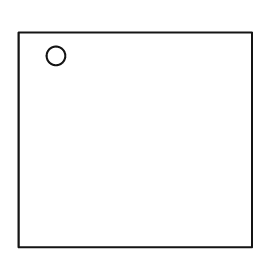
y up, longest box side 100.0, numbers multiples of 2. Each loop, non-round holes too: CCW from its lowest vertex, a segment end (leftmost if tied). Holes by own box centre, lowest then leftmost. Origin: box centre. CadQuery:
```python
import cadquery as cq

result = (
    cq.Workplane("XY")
    .moveTo(-50.0, -46.0)
    .lineTo(50.0, -46.0)
    .lineTo(50.0, 46.0)
    .lineTo(-50.0, 46.0)
    .close()
    .moveTo(-34.0, 36.0)
    .circle(4.0)
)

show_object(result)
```